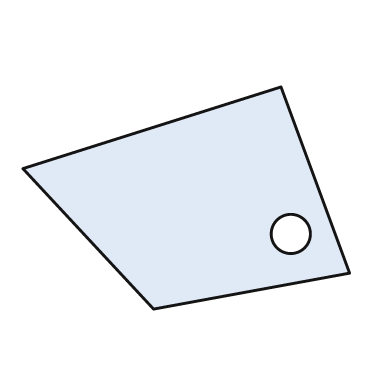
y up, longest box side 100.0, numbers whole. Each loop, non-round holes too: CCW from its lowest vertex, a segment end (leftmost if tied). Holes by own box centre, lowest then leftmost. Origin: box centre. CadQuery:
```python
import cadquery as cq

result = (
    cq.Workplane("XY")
    .moveTo(-10.0, -34.0)
    .lineTo(50.0, -23.0)
    .lineTo(29.0, 34.0)
    .lineTo(-50.0, 9.0)
    .close()
    .moveTo(32.0, -11.0)
    .circle(6.0)
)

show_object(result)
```